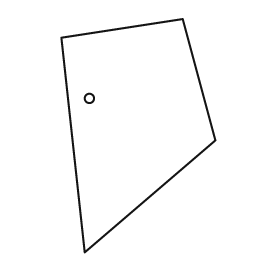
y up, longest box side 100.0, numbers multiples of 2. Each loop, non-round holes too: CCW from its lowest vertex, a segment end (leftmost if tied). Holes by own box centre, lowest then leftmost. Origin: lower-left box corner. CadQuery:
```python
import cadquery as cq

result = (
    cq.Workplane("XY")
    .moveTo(10.0, 0.0)
    .lineTo(66.0, 48.0)
    .lineTo(52.0, 100.0)
    .lineTo(0.0, 92.0)
    .close()
    .moveTo(12.0, 66.0)
    .circle(2.0)
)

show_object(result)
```